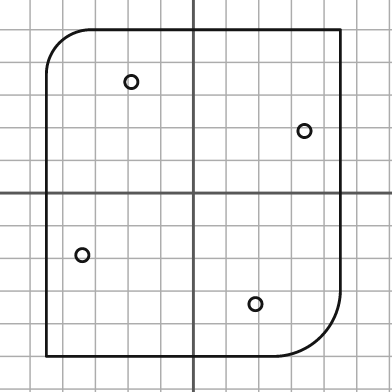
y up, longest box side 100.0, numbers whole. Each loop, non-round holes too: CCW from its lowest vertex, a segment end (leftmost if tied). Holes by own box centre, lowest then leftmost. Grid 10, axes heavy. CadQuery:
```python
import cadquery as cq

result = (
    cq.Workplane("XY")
    .moveTo(-45.0, -50.0)
    .lineTo(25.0, -50.0)
    .threePointArc((39.0, -44.0), (45.0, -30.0))
    .lineTo(45.0, 50.0)
    .lineTo(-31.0, 50.0)
    .threePointArc((-41.0, 46.0), (-45.0, 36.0))
    .close()
    .moveTo(19.0, -34.0)
    .circle(2.0)
    .moveTo(-34.0, -19.0)
    .circle(2.0)
    .moveTo(34.0, 19.0)
    .circle(2.0)
    .moveTo(-19.0, 34.0)
    .circle(2.0)
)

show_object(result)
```